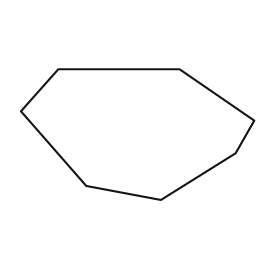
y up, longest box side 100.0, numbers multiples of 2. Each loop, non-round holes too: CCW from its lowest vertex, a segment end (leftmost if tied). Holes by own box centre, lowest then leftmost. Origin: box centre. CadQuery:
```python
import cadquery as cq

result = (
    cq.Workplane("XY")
    .moveTo(10.0, -28.0)
    .lineTo(42.0, -8.0)
    .lineTo(50.0, 6.0)
    .lineTo(18.0, 28.0)
    .lineTo(-34.0, 28.0)
    .lineTo(-50.0, 10.0)
    .lineTo(-22.0, -22.0)
    .close()
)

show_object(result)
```